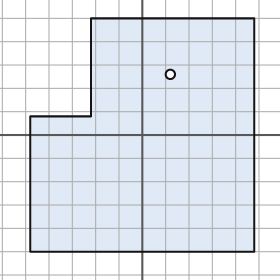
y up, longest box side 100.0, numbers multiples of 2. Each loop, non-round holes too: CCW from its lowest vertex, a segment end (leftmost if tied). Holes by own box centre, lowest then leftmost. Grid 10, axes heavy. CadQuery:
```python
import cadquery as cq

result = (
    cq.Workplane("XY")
    .moveTo(-48.0, -50.0)
    .lineTo(48.0, -50.0)
    .lineTo(48.0, 50.0)
    .lineTo(-22.0, 50.0)
    .lineTo(-22.0, 8.0)
    .lineTo(-48.0, 8.0)
    .close()
    .moveTo(12.0, 26.0)
    .circle(2.0)
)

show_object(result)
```